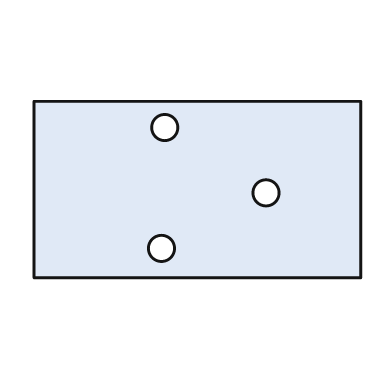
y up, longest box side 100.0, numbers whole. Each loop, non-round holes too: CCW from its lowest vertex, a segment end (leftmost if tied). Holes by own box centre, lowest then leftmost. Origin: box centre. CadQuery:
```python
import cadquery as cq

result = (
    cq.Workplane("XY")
    .moveTo(-50.0, -27.0)
    .lineTo(50.0, -27.0)
    .lineTo(50.0, 27.0)
    .lineTo(-50.0, 27.0)
    .close()
    .moveTo(-11.0, -18.0)
    .circle(4.0)
    .moveTo(21.0, -1.0)
    .circle(4.0)
    .moveTo(-10.0, 19.0)
    .circle(4.0)
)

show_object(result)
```